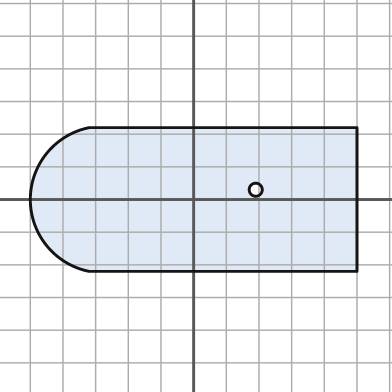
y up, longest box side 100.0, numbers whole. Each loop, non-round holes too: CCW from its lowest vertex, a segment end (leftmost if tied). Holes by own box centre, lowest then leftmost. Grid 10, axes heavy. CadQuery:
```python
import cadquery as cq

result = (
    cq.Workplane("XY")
    .moveTo(-32.0, -22.0)
    .lineTo(50.0, -22.0)
    .lineTo(50.0, 22.0)
    .lineTo(-32.0, 22.0)
    .threePointArc((-50.0, 0.0), (-32.0, -22.0))
    .close()
    .moveTo(19.0, 3.0)
    .circle(2.0)
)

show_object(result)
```